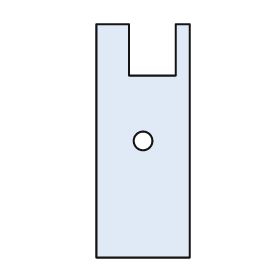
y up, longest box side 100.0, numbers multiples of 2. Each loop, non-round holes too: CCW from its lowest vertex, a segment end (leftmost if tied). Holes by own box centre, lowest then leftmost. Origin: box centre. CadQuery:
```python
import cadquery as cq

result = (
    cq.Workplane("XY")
    .moveTo(-20.0, -50.0)
    .lineTo(20.0, -50.0)
    .lineTo(20.0, 50.0)
    .lineTo(14.0, 50.0)
    .lineTo(14.0, 28.0)
    .lineTo(-6.0, 28.0)
    .lineTo(-6.0, 50.0)
    .lineTo(-20.0, 50.0)
    .close()
    .moveTo(0.0, 0.0)
    .circle(4.0)
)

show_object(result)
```